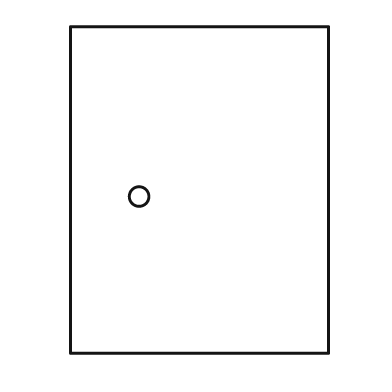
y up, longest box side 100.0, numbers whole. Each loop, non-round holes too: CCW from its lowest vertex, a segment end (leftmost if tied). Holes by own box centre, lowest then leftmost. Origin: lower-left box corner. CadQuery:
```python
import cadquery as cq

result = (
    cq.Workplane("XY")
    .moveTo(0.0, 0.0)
    .lineTo(79.0, 0.0)
    .lineTo(79.0, 100.0)
    .lineTo(0.0, 100.0)
    .close()
    .moveTo(21.0, 48.0)
    .circle(3.0)
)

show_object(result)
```